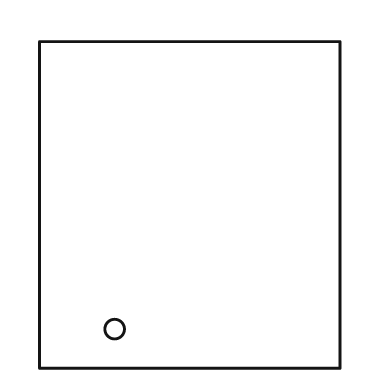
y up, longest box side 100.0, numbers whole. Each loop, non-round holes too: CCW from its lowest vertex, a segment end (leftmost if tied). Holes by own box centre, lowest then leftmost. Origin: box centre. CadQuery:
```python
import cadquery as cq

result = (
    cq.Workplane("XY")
    .moveTo(-46.0, -50.0)
    .lineTo(46.0, -50.0)
    .lineTo(46.0, 50.0)
    .lineTo(-46.0, 50.0)
    .close()
    .moveTo(-23.0, -38.0)
    .circle(3.0)
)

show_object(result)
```